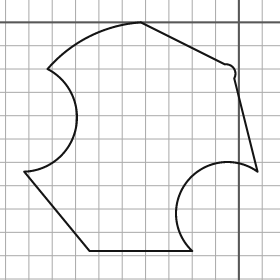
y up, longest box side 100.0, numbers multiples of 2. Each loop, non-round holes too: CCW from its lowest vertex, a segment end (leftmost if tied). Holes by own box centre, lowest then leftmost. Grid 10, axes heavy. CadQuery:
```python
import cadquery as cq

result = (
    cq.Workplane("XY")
    .moveTo(-64.0, -98.0)
    .lineTo(-20.0, -98.0)
    .threePointArc((-22.0, -68.0), (8.0, -64.0))
    .lineTo(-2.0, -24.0)
    .threePointArc((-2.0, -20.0), (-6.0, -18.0))
    .lineTo(-42.0, 0.0)
    .threePointArc((-64.0, -6.0), (-82.0, -20.0))
    .threePointArc((-70.0, -46.0), (-92.0, -64.0))
    .close()
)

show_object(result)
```